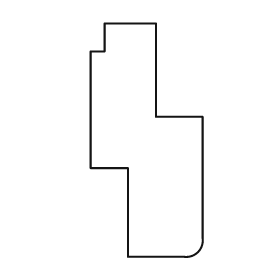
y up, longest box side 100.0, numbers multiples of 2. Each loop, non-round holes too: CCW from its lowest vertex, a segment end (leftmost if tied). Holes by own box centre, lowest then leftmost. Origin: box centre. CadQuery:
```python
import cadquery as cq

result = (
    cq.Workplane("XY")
    .moveTo(-8.0, -50.0)
    .lineTo(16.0, -50.0)
    .threePointArc((22.0, -48.0), (24.0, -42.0))
    .lineTo(24.0, 10.0)
    .lineTo(4.0, 10.0)
    .lineTo(4.0, 50.0)
    .lineTo(-18.0, 50.0)
    .lineTo(-18.0, 38.0)
    .lineTo(-24.0, 38.0)
    .lineTo(-24.0, -12.0)
    .lineTo(-8.0, -12.0)
    .close()
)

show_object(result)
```